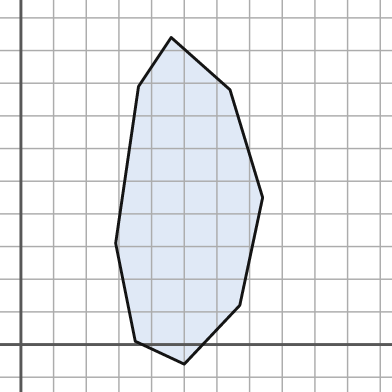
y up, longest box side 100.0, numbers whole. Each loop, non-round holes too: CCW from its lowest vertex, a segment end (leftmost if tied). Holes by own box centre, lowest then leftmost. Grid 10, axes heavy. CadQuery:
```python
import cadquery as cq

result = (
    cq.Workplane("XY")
    .moveTo(50.0, -6.0)
    .lineTo(67.0, 12.0)
    .lineTo(74.0, 45.0)
    .lineTo(64.0, 78.0)
    .lineTo(46.0, 94.0)
    .lineTo(36.0, 79.0)
    .lineTo(29.0, 31.0)
    .lineTo(35.0, 1.0)
    .close()
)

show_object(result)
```